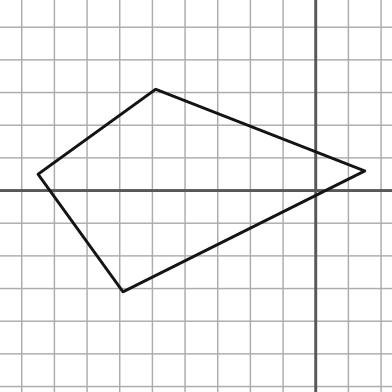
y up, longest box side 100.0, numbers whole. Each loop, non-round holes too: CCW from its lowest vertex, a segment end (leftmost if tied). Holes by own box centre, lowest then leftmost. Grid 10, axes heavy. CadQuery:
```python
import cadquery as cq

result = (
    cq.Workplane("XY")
    .moveTo(-59.0, -31.0)
    .lineTo(15.0, 6.0)
    .lineTo(-49.0, 31.0)
    .lineTo(-85.0, 5.0)
    .close()
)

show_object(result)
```